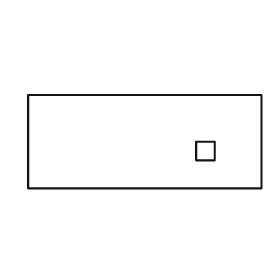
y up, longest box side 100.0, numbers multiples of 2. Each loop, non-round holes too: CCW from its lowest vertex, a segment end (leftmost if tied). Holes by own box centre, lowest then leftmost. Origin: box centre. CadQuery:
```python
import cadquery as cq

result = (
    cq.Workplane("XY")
    .moveTo(-50.0, -20.0)
    .lineTo(50.0, -20.0)
    .lineTo(50.0, 20.0)
    .lineTo(-50.0, 20.0)
    .close()
    .moveTo(22.0, -8.0)
    .lineTo(30.0, -8.0)
    .lineTo(30.0, 0.0)
    .lineTo(22.0, 0.0)
    .close()
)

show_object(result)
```